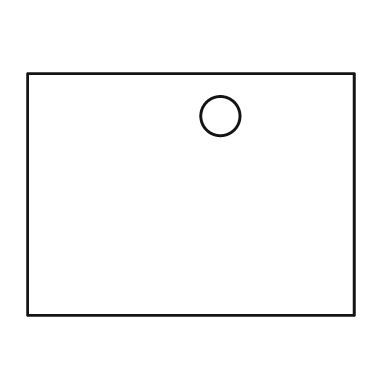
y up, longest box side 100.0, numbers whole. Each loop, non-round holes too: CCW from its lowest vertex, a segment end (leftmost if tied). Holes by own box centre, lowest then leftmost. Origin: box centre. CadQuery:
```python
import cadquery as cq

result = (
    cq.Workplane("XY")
    .moveTo(-50.0, -37.0)
    .lineTo(50.0, -37.0)
    .lineTo(50.0, 37.0)
    .lineTo(-50.0, 37.0)
    .close()
    .moveTo(9.0, 24.0)
    .circle(6.0)
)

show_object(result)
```